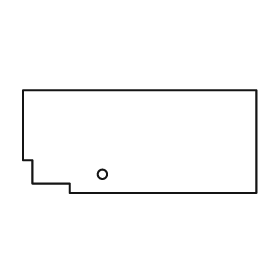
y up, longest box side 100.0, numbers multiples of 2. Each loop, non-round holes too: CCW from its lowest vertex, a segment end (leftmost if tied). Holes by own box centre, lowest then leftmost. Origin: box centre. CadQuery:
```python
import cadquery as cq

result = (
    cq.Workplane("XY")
    .moveTo(-30.0, -22.0)
    .lineTo(50.0, -22.0)
    .lineTo(50.0, 22.0)
    .lineTo(-50.0, 22.0)
    .lineTo(-50.0, -8.0)
    .lineTo(-46.0, -8.0)
    .lineTo(-46.0, -18.0)
    .lineTo(-30.0, -18.0)
    .close()
    .moveTo(-16.0, -14.0)
    .circle(2.0)
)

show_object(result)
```